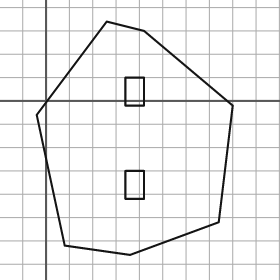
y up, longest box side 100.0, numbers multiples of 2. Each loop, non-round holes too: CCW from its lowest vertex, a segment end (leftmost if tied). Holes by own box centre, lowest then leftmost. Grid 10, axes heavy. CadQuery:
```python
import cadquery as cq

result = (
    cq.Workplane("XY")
    .moveTo(36.0, -66.0)
    .lineTo(74.0, -52.0)
    .lineTo(80.0, -2.0)
    .lineTo(42.0, 30.0)
    .lineTo(26.0, 34.0)
    .lineTo(-4.0, -6.0)
    .lineTo(8.0, -62.0)
    .close()
    .moveTo(34.0, -42.0)
    .lineTo(42.0, -42.0)
    .lineTo(42.0, -30.0)
    .lineTo(34.0, -30.0)
    .close()
    .moveTo(34.0, -2.0)
    .lineTo(42.0, -2.0)
    .lineTo(42.0, 10.0)
    .lineTo(34.0, 10.0)
    .close()
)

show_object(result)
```